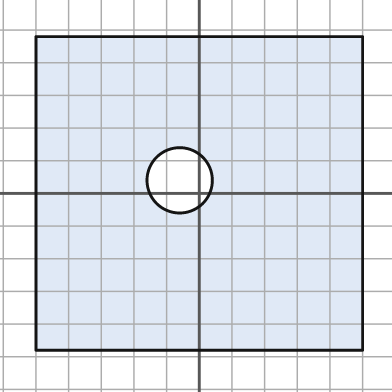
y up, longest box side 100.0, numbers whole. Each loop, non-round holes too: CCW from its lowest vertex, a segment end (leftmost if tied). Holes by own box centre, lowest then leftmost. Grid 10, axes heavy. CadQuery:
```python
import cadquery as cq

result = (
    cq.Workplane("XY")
    .moveTo(-50.0, -48.0)
    .lineTo(50.0, -48.0)
    .lineTo(50.0, 48.0)
    .lineTo(-50.0, 48.0)
    .close()
    .moveTo(-6.0, 4.0)
    .circle(10.0)
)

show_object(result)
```